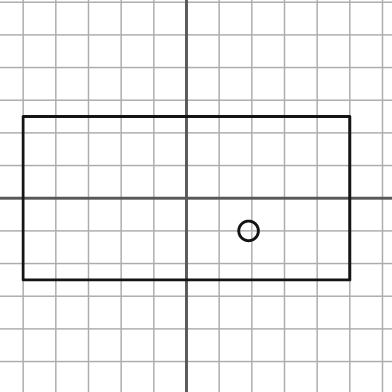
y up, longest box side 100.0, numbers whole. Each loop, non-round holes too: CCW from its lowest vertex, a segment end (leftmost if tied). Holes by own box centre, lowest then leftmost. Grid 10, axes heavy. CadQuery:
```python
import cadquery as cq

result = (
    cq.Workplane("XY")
    .moveTo(-50.0, -25.0)
    .lineTo(50.0, -25.0)
    .lineTo(50.0, 25.0)
    .lineTo(-50.0, 25.0)
    .close()
    .moveTo(19.0, -10.0)
    .circle(3.0)
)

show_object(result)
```